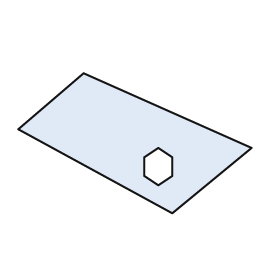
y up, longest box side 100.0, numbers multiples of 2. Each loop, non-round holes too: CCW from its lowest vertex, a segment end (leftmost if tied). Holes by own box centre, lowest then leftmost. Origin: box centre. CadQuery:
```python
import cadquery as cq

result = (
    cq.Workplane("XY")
    .moveTo(16.0, -30.0)
    .lineTo(50.0, -2.0)
    .lineTo(-22.0, 30.0)
    .lineTo(-50.0, 6.0)
    .close()
    .moveTo(10.0, -18.0)
    .lineTo(16.0, -14.0)
    .lineTo(16.0, -6.0)
    .lineTo(10.0, -2.0)
    .lineTo(4.0, -6.0)
    .lineTo(4.0, -14.0)
    .close()
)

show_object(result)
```